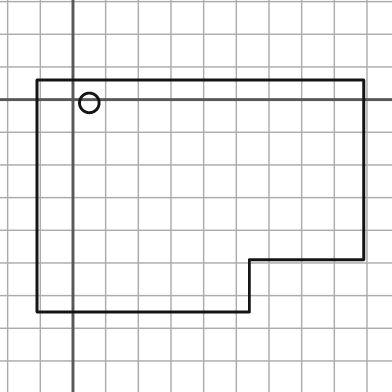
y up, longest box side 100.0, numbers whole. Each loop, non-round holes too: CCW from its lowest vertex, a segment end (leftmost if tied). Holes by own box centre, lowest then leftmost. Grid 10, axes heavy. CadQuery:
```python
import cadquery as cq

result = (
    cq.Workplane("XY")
    .moveTo(-11.0, -65.0)
    .lineTo(54.0, -65.0)
    .lineTo(54.0, -49.0)
    .lineTo(89.0, -49.0)
    .lineTo(89.0, 6.0)
    .lineTo(-11.0, 6.0)
    .close()
    .moveTo(5.0, -1.0)
    .circle(3.0)
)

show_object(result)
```